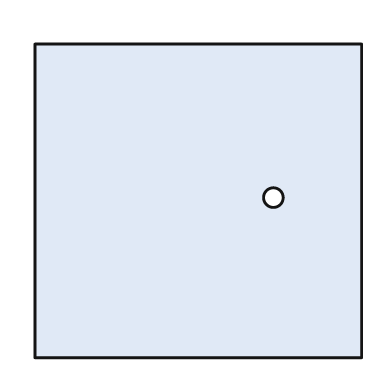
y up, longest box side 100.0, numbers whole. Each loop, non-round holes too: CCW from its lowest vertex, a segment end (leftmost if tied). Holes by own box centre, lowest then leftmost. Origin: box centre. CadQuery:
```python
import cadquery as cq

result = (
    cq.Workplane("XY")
    .moveTo(-50.0, -48.0)
    .lineTo(50.0, -48.0)
    .lineTo(50.0, 48.0)
    .lineTo(-50.0, 48.0)
    .close()
    .moveTo(23.0, 1.0)
    .circle(3.0)
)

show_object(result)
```